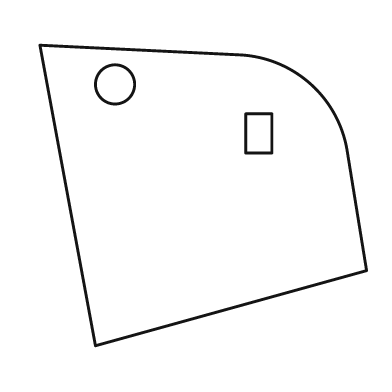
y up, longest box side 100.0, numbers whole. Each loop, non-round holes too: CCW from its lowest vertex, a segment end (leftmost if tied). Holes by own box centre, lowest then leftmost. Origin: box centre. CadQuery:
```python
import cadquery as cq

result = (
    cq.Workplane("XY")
    .moveTo(-33.0, -46.0)
    .lineTo(50.0, -23.0)
    .lineTo(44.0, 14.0)
    .threePointArc((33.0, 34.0), (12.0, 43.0))
    .lineTo(-50.0, 46.0)
    .close()
    .moveTo(13.0, 13.0)
    .lineTo(21.0, 13.0)
    .lineTo(21.0, 25.0)
    .lineTo(13.0, 25.0)
    .close()
    .moveTo(-27.0, 34.0)
    .circle(6.0)
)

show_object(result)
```